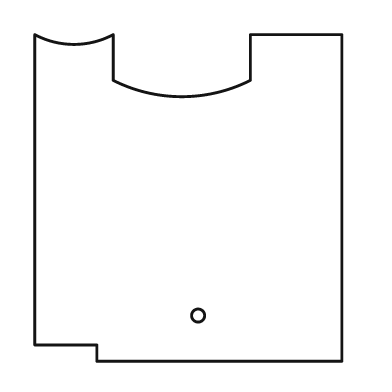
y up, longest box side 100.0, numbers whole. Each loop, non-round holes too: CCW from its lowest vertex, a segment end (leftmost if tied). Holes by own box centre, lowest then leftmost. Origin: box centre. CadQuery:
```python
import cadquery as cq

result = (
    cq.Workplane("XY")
    .moveTo(-28.0, -50.0)
    .lineTo(47.0, -50.0)
    .lineTo(47.0, 50.0)
    .lineTo(19.0, 50.0)
    .lineTo(19.0, 36.0)
    .threePointArc((-2.0, 31.0), (-23.0, 36.0))
    .lineTo(-23.0, 50.0)
    .threePointArc((-35.0, 47.0), (-47.0, 50.0))
    .lineTo(-47.0, -45.0)
    .lineTo(-28.0, -45.0)
    .close()
    .moveTo(3.0, -36.0)
    .circle(2.0)
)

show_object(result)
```